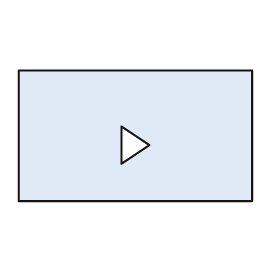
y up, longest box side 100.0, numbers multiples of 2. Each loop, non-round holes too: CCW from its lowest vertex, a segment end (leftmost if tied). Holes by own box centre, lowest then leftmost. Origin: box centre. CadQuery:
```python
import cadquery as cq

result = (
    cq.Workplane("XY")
    .moveTo(-50.0, -28.0)
    .lineTo(50.0, -28.0)
    .lineTo(50.0, 28.0)
    .lineTo(-50.0, 28.0)
    .close()
    .moveTo(-6.0, -12.0)
    .lineTo(6.0, -4.0)
    .lineTo(-6.0, 4.0)
    .close()
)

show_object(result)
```